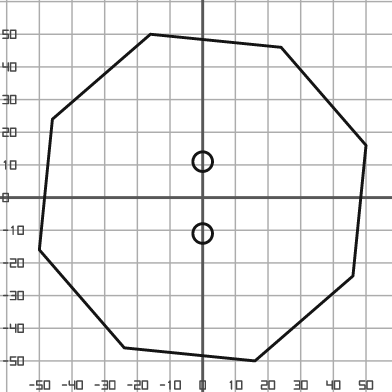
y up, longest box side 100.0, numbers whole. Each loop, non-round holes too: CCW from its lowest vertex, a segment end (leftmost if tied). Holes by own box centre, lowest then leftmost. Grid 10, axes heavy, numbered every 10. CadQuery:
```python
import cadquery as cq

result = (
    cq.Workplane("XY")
    .moveTo(16.0, -50.0)
    .lineTo(46.0, -24.0)
    .lineTo(50.0, 16.0)
    .lineTo(24.0, 46.0)
    .lineTo(-16.0, 50.0)
    .lineTo(-46.0, 24.0)
    .lineTo(-50.0, -16.0)
    .lineTo(-24.0, -46.0)
    .close()
    .moveTo(0.0, -11.0)
    .circle(3.0)
    .moveTo(0.0, 11.0)
    .circle(3.0)
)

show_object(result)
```